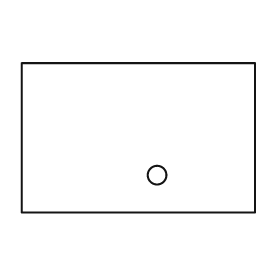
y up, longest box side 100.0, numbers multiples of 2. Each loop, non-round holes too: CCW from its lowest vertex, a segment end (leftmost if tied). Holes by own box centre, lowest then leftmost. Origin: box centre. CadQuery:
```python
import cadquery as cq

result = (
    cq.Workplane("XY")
    .moveTo(-50.0, -32.0)
    .lineTo(50.0, -32.0)
    .lineTo(50.0, 32.0)
    .lineTo(-50.0, 32.0)
    .close()
    .moveTo(8.0, -16.0)
    .circle(4.0)
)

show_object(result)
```